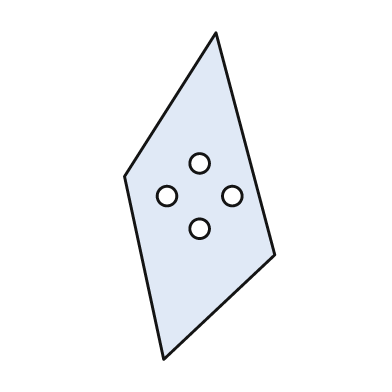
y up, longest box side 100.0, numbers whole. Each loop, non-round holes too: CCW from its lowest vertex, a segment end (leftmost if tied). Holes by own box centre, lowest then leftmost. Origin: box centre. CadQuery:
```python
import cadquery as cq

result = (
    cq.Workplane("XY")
    .moveTo(-11.0, -50.0)
    .lineTo(23.0, -18.0)
    .lineTo(5.0, 50.0)
    .lineTo(-23.0, 6.0)
    .close()
    .moveTo(0.0, -10.0)
    .circle(3.0)
    .moveTo(-10.0, 0.0)
    .circle(3.0)
    .moveTo(10.0, 0.0)
    .circle(3.0)
    .moveTo(0.0, 10.0)
    .circle(3.0)
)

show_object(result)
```